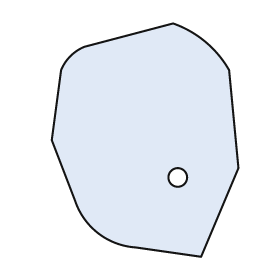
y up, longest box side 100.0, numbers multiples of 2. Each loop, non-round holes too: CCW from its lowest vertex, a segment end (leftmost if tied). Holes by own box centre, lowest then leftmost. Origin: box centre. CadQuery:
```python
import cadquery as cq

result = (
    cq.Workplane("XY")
    .moveTo(24.0, -50.0)
    .lineTo(40.0, -12.0)
    .lineTo(36.0, 30.0)
    .threePointArc((26.0, 42.0), (12.0, 50.0))
    .lineTo(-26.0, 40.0)
    .threePointArc((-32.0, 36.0), (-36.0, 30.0))
    .lineTo(-40.0, 0.0)
    .lineTo(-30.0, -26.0)
    .threePointArc((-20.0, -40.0), (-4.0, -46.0))
    .close()
    .moveTo(14.0, -16.0)
    .circle(4.0)
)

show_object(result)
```